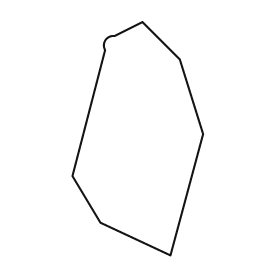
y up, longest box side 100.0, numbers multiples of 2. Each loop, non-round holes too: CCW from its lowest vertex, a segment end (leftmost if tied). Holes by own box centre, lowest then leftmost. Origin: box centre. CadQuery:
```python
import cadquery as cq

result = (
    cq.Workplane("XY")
    .moveTo(14.0, -50.0)
    .lineTo(28.0, 2.0)
    .lineTo(18.0, 34.0)
    .lineTo(2.0, 50.0)
    .lineTo(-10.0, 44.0)
    .threePointArc((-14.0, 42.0), (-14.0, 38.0))
    .lineTo(-28.0, -16.0)
    .lineTo(-16.0, -36.0)
    .close()
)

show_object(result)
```